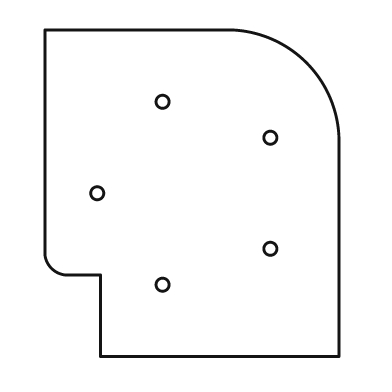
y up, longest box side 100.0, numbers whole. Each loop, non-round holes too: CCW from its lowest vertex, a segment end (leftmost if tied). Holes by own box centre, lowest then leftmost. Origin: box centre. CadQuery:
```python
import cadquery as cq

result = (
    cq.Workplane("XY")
    .moveTo(-28.0, -50.0)
    .lineTo(45.0, -50.0)
    .lineTo(45.0, 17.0)
    .threePointArc((35.0, 40.0), (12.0, 50.0))
    .lineTo(-45.0, 50.0)
    .lineTo(-45.0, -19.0)
    .threePointArc((-43.0, -23.0), (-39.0, -25.0))
    .lineTo(-28.0, -25.0)
    .close()
    .moveTo(-9.0, -28.0)
    .circle(2.0)
    .moveTo(24.0, -17.0)
    .circle(2.0)
    .moveTo(-29.0, 0.0)
    .circle(2.0)
    .moveTo(24.0, 17.0)
    .circle(2.0)
    .moveTo(-9.0, 28.0)
    .circle(2.0)
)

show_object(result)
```